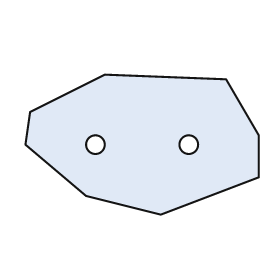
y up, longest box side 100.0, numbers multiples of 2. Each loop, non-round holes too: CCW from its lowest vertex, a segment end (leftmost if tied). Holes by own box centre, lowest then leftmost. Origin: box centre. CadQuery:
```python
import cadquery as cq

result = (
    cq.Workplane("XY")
    .moveTo(8.0, -30.0)
    .lineTo(50.0, -14.0)
    .lineTo(50.0, 4.0)
    .lineTo(36.0, 28.0)
    .lineTo(-16.0, 30.0)
    .lineTo(-48.0, 14.0)
    .lineTo(-50.0, 0.0)
    .lineTo(-24.0, -22.0)
    .close()
    .moveTo(-20.0, 0.0)
    .circle(4.0)
    .moveTo(20.0, 0.0)
    .circle(4.0)
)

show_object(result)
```